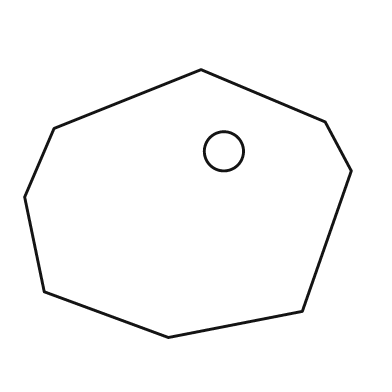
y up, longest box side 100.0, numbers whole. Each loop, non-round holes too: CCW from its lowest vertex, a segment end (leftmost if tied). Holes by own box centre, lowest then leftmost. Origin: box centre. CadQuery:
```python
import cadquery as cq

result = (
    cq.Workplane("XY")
    .moveTo(-6.0, -41.0)
    .lineTo(35.0, -33.0)
    .lineTo(50.0, 10.0)
    .lineTo(42.0, 25.0)
    .lineTo(4.0, 41.0)
    .lineTo(-41.0, 23.0)
    .lineTo(-50.0, 2.0)
    .lineTo(-44.0, -27.0)
    .close()
    .moveTo(11.0, 16.0)
    .circle(6.0)
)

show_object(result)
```